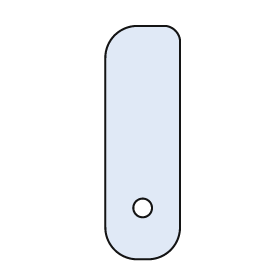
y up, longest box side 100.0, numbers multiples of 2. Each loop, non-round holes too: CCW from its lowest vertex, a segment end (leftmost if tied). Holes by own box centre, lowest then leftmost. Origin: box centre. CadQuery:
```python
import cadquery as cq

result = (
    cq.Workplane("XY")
    .moveTo(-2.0, -50.0)
    .lineTo(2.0, -50.0)
    .threePointArc((12.0, -46.0), (16.0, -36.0))
    .lineTo(16.0, 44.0)
    .threePointArc((14.0, 48.0), (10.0, 50.0))
    .lineTo(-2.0, 50.0)
    .threePointArc((-12.0, 46.0), (-16.0, 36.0))
    .lineTo(-16.0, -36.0)
    .threePointArc((-12.0, -46.0), (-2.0, -50.0))
    .close()
    .moveTo(0.0, -28.0)
    .circle(4.0)
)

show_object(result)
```